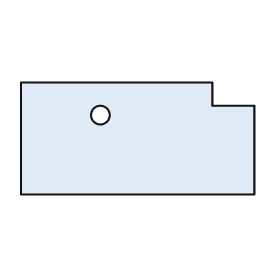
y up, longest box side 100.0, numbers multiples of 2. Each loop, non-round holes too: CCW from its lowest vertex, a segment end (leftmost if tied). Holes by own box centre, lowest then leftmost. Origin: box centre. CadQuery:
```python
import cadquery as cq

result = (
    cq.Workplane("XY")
    .moveTo(-50.0, -24.0)
    .lineTo(50.0, -24.0)
    .lineTo(50.0, 14.0)
    .lineTo(32.0, 14.0)
    .lineTo(32.0, 24.0)
    .lineTo(-50.0, 24.0)
    .close()
    .moveTo(-16.0, 10.0)
    .circle(4.0)
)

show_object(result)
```